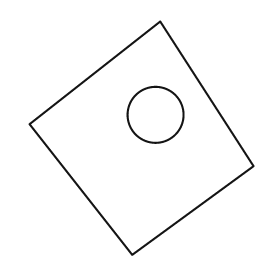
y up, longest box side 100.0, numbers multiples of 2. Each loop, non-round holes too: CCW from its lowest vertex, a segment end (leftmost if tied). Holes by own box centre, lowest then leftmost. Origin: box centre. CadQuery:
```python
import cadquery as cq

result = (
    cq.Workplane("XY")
    .moveTo(-4.0, -50.0)
    .lineTo(48.0, -12.0)
    .lineTo(8.0, 50.0)
    .lineTo(-48.0, 6.0)
    .close()
    .moveTo(6.0, 10.0)
    .circle(12.0)
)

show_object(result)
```